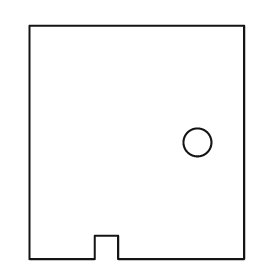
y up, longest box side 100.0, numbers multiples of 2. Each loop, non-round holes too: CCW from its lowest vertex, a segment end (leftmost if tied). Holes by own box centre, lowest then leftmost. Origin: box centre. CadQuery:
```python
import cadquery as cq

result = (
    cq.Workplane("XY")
    .moveTo(-46.0, -50.0)
    .lineTo(-18.0, -50.0)
    .lineTo(-18.0, -40.0)
    .lineTo(-8.0, -40.0)
    .lineTo(-8.0, -50.0)
    .lineTo(46.0, -50.0)
    .lineTo(46.0, 50.0)
    .lineTo(-46.0, 50.0)
    .close()
    .moveTo(26.0, 0.0)
    .circle(6.0)
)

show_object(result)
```